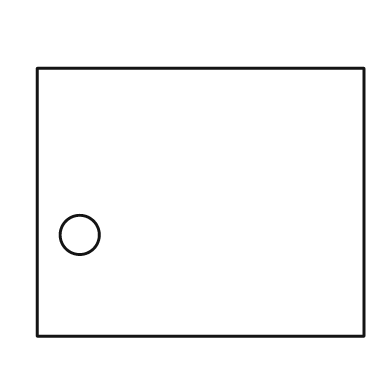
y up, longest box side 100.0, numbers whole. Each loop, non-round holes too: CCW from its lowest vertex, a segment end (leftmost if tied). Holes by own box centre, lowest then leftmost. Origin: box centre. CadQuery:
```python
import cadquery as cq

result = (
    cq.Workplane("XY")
    .moveTo(-50.0, -41.0)
    .lineTo(50.0, -41.0)
    .lineTo(50.0, 41.0)
    .lineTo(-50.0, 41.0)
    .close()
    .moveTo(-37.0, -10.0)
    .circle(6.0)
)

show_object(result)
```